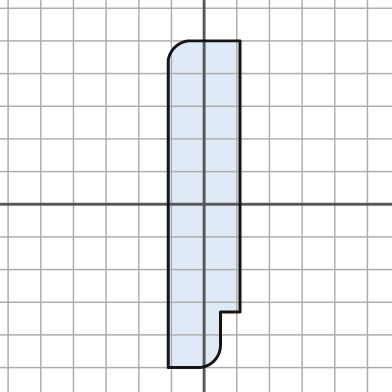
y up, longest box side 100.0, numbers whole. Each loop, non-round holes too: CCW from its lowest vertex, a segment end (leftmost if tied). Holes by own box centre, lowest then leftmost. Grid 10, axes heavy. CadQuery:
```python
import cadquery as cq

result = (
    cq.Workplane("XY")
    .moveTo(-11.0, -50.0)
    .lineTo(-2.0, -50.0)
    .threePointArc((3.0, -48.0), (5.0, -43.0))
    .lineTo(5.0, -33.0)
    .lineTo(11.0, -33.0)
    .lineTo(11.0, 50.0)
    .lineTo(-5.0, 50.0)
    .threePointArc((-9.0, 48.0), (-11.0, 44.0))
    .close()
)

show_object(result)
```